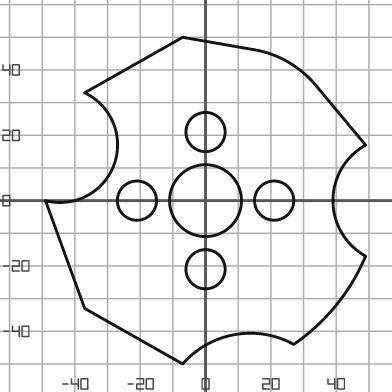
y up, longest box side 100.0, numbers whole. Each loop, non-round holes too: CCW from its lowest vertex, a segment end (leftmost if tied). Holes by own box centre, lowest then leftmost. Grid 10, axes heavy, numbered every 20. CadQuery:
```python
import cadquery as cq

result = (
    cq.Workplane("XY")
    .moveTo(-7.0, -50.0)
    .threePointArc((9.0, -41.0), (27.0, -44.0))
    .threePointArc((40.0, -32.0), (49.0, -17.0))
    .threePointArc((39.0, 0.0), (49.0, 17.0))
    .lineTo(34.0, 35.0)
    .threePointArc((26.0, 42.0), (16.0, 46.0))
    .lineTo(-7.0, 50.0)
    .lineTo(-37.0, 33.0)
    .threePointArc((-28.0, 11.0), (-49.0, 0.0))
    .lineTo(-37.0, -33.0)
    .close()
    .moveTo(0.0, -21.0)
    .circle(6.0)
    .moveTo(-21.0, 0.0)
    .circle(6.0)
    .moveTo(0.0, 0.0)
    .circle(11.0)
    .moveTo(21.0, 0.0)
    .circle(6.0)
    .moveTo(0.0, 21.0)
    .circle(6.0)
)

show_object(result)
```